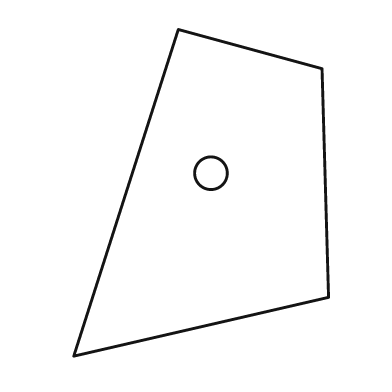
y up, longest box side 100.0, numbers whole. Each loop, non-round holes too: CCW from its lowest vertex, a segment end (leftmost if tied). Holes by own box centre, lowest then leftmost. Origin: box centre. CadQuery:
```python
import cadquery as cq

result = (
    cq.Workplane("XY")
    .moveTo(-39.0, -50.0)
    .lineTo(39.0, -32.0)
    .lineTo(37.0, 38.0)
    .lineTo(-7.0, 50.0)
    .close()
    .moveTo(3.0, 6.0)
    .circle(5.0)
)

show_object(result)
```